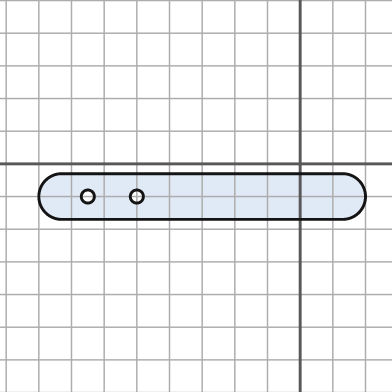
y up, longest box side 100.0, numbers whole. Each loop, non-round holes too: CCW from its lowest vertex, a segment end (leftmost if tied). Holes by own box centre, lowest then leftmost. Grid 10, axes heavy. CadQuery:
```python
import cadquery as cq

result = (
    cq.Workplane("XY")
    .moveTo(-73.0, -17.0)
    .lineTo(13.0, -17.0)
    .threePointArc((20.0, -10.0), (13.0, -3.0))
    .lineTo(-73.0, -3.0)
    .threePointArc((-80.0, -10.0), (-73.0, -17.0))
    .close()
    .moveTo(-65.0, -10.0)
    .circle(2.0)
    .moveTo(-50.0, -10.0)
    .circle(2.0)
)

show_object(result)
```